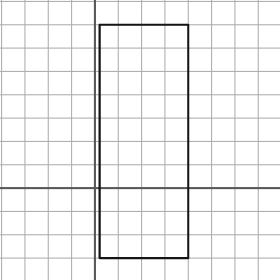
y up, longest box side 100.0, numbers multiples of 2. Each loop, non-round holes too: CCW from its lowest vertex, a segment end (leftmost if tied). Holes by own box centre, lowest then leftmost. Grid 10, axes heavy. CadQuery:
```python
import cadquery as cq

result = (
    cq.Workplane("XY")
    .moveTo(2.0, -30.0)
    .lineTo(40.0, -30.0)
    .lineTo(40.0, 70.0)
    .lineTo(2.0, 70.0)
    .close()
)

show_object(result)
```